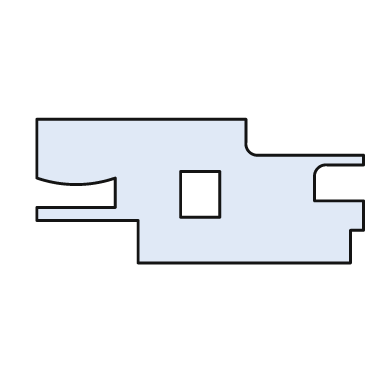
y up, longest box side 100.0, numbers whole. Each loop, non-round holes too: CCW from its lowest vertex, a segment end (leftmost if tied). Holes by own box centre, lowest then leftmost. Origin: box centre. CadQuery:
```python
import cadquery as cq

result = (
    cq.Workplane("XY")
    .moveTo(-19.0, -22.0)
    .lineTo(46.0, -22.0)
    .lineTo(46.0, -12.0)
    .lineTo(50.0, -12.0)
    .lineTo(50.0, -3.0)
    .lineTo(35.0, -3.0)
    .lineTo(35.0, 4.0)
    .threePointArc((36.0, 7.0), (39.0, 8.0))
    .lineTo(50.0, 8.0)
    .lineTo(50.0, 11.0)
    .lineTo(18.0, 11.0)
    .threePointArc((15.0, 12.0), (14.0, 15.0))
    .lineTo(14.0, 22.0)
    .lineTo(-50.0, 22.0)
    .lineTo(-50.0, 4.0)
    .threePointArc((-38.0, 2.0), (-26.0, 4.0))
    .lineTo(-26.0, -5.0)
    .lineTo(-50.0, -5.0)
    .lineTo(-50.0, -9.0)
    .lineTo(-19.0, -9.0)
    .close()
    .moveTo(-6.0, -8.0)
    .lineTo(6.0, -8.0)
    .lineTo(6.0, 6.0)
    .lineTo(-6.0, 6.0)
    .close()
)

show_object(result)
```